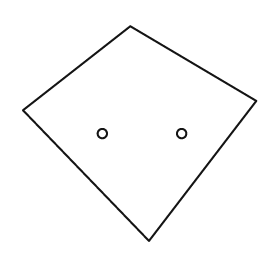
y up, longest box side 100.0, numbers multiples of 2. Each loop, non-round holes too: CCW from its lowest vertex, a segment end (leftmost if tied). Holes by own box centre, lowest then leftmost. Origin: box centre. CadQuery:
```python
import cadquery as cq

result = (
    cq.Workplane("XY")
    .moveTo(4.0, -46.0)
    .lineTo(50.0, 14.0)
    .lineTo(-4.0, 46.0)
    .lineTo(-50.0, 10.0)
    .close()
    .moveTo(-16.0, 0.0)
    .circle(2.0)
    .moveTo(18.0, 0.0)
    .circle(2.0)
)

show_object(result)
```